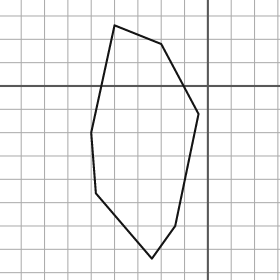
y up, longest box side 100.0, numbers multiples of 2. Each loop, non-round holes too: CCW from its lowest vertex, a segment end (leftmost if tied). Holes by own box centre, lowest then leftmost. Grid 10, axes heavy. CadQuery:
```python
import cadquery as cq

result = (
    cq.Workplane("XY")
    .moveTo(-24.0, -74.0)
    .lineTo(-14.0, -60.0)
    .lineTo(-4.0, -12.0)
    .lineTo(-20.0, 18.0)
    .lineTo(-40.0, 26.0)
    .lineTo(-50.0, -20.0)
    .lineTo(-48.0, -46.0)
    .close()
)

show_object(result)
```